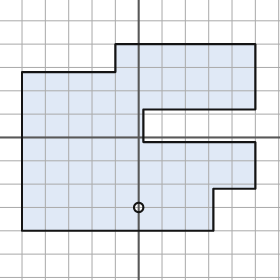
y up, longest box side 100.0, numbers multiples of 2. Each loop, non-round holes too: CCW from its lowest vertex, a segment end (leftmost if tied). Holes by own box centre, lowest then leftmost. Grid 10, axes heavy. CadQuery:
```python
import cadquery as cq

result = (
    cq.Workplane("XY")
    .moveTo(-50.0, -40.0)
    .lineTo(32.0, -40.0)
    .lineTo(32.0, -22.0)
    .lineTo(50.0, -22.0)
    .lineTo(50.0, -2.0)
    .lineTo(2.0, -2.0)
    .lineTo(2.0, 12.0)
    .lineTo(50.0, 12.0)
    .lineTo(50.0, 40.0)
    .lineTo(-10.0, 40.0)
    .lineTo(-10.0, 28.0)
    .lineTo(-50.0, 28.0)
    .close()
    .moveTo(0.0, -30.0)
    .circle(2.0)
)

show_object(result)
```